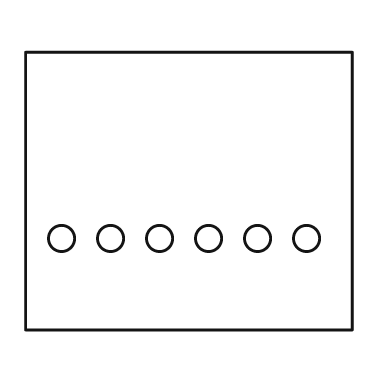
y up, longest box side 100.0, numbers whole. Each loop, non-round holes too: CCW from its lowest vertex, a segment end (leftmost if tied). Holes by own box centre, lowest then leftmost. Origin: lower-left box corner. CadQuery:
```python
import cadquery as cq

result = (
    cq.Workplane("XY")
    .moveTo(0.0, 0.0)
    .lineTo(100.0, 0.0)
    .lineTo(100.0, 85.0)
    .lineTo(0.0, 85.0)
    .close()
    .moveTo(11.0, 28.0)
    .circle(4.0)
    .moveTo(26.0, 28.0)
    .circle(4.0)
    .moveTo(41.0, 28.0)
    .circle(4.0)
    .moveTo(56.0, 28.0)
    .circle(4.0)
    .moveTo(71.0, 28.0)
    .circle(4.0)
    .moveTo(86.0, 28.0)
    .circle(4.0)
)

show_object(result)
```